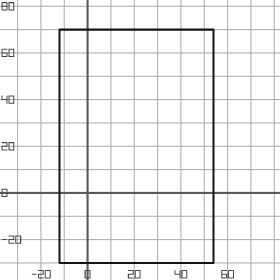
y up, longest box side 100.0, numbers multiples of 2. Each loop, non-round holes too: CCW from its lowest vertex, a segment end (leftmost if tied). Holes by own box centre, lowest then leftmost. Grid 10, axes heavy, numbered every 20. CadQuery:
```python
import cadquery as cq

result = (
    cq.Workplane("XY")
    .moveTo(-12.0, -30.0)
    .lineTo(54.0, -30.0)
    .lineTo(54.0, 70.0)
    .lineTo(-12.0, 70.0)
    .close()
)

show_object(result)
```